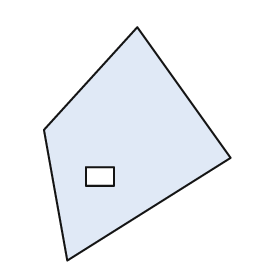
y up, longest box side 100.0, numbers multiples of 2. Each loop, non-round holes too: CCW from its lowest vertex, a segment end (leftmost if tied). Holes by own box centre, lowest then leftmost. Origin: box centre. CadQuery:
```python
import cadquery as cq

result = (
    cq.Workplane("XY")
    .moveTo(-30.0, -50.0)
    .lineTo(40.0, -6.0)
    .lineTo(0.0, 50.0)
    .lineTo(-40.0, 6.0)
    .close()
    .moveTo(-22.0, -18.0)
    .lineTo(-10.0, -18.0)
    .lineTo(-10.0, -10.0)
    .lineTo(-22.0, -10.0)
    .close()
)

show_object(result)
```